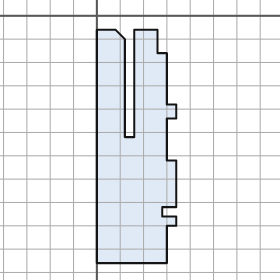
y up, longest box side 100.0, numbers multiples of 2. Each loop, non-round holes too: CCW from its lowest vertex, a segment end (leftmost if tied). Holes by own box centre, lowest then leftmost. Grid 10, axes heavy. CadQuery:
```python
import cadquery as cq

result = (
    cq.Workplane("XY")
    .moveTo(0.0, -106.0)
    .lineTo(30.0, -106.0)
    .lineTo(30.0, -90.0)
    .lineTo(34.0, -90.0)
    .lineTo(34.0, -86.0)
    .lineTo(28.0, -86.0)
    .lineTo(28.0, -82.0)
    .lineTo(34.0, -82.0)
    .lineTo(34.0, -62.0)
    .lineTo(30.0, -62.0)
    .lineTo(30.0, -44.0)
    .lineTo(34.0, -44.0)
    .lineTo(34.0, -38.0)
    .lineTo(30.0, -38.0)
    .lineTo(30.0, -16.0)
    .lineTo(26.0, -16.0)
    .lineTo(26.0, -6.0)
    .lineTo(16.0, -6.0)
    .lineTo(16.0, -52.0)
    .lineTo(12.0, -52.0)
    .lineTo(12.0, -10.0)
    .lineTo(8.0, -6.0)
    .lineTo(0.0, -6.0)
    .close()
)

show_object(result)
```